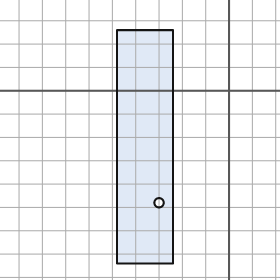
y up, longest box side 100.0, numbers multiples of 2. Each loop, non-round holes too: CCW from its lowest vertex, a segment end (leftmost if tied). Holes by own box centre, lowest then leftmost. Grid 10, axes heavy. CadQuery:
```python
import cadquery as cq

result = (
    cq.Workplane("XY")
    .moveTo(-48.0, -74.0)
    .lineTo(-24.0, -74.0)
    .lineTo(-24.0, 26.0)
    .lineTo(-48.0, 26.0)
    .close()
    .moveTo(-30.0, -48.0)
    .circle(2.0)
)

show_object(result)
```